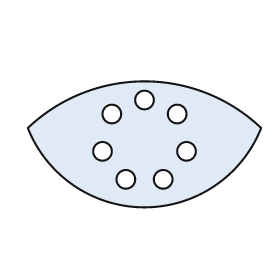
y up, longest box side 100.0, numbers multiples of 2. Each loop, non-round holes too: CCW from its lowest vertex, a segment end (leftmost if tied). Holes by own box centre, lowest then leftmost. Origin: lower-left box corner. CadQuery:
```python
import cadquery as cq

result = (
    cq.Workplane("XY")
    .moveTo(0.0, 34.0)
    .threePointArc((50.0, 0.0), (100.0, 34.0))
    .threePointArc((50.0, 54.0), (0.0, 34.0))
    .close()
    .moveTo(42.0, 12.0)
    .circle(4.0)
    .moveTo(58.0, 12.0)
    .circle(4.0)
    .moveTo(32.0, 24.0)
    .circle(4.0)
    .moveTo(68.0, 24.0)
    .circle(4.0)
    .moveTo(36.0, 40.0)
    .circle(4.0)
    .moveTo(64.0, 40.0)
    .circle(4.0)
    .moveTo(50.0, 46.0)
    .circle(4.0)
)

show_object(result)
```